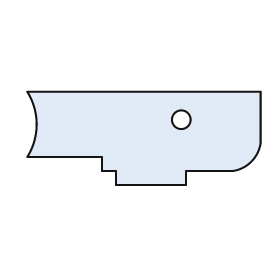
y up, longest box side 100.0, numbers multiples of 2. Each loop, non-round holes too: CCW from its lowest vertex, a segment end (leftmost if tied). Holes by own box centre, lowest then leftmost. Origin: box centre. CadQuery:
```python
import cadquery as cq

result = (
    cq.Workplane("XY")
    .moveTo(-12.0, -20.0)
    .lineTo(18.0, -20.0)
    .lineTo(18.0, -14.0)
    .lineTo(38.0, -14.0)
    .threePointArc((46.0, -10.0), (50.0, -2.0))
    .lineTo(50.0, 20.0)
    .lineTo(-50.0, 20.0)
    .threePointArc((-46.0, 6.0), (-50.0, -8.0))
    .lineTo(-18.0, -8.0)
    .lineTo(-18.0, -14.0)
    .lineTo(-12.0, -14.0)
    .close()
    .moveTo(16.0, 8.0)
    .circle(4.0)
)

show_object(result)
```